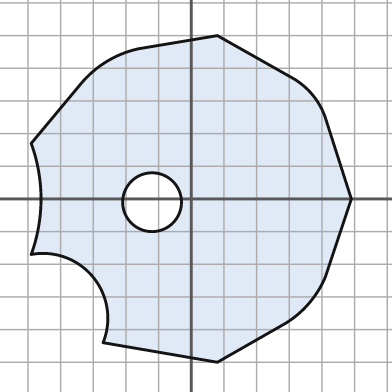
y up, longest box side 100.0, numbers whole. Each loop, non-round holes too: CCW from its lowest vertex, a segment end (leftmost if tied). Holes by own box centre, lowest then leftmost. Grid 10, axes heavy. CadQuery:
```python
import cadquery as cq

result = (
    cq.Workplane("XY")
    .moveTo(8.0, -50.0)
    .lineTo(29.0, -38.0)
    .threePointArc((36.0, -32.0), (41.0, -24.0))
    .lineTo(49.0, 0.0)
    .lineTo(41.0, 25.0)
    .threePointArc((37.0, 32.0), (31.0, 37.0))
    .lineTo(8.0, 50.0)
    .lineTo(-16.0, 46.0)
    .threePointArc((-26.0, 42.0), (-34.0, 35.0))
    .lineTo(-49.0, 17.0)
    .threePointArc((-46.0, 0.0), (-49.0, -17.0))
    .threePointArc((-30.0, -24.0), (-27.0, -44.0))
    .close()
    .moveTo(-12.0, -1.0)
    .circle(9.0)
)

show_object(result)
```